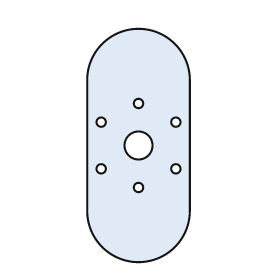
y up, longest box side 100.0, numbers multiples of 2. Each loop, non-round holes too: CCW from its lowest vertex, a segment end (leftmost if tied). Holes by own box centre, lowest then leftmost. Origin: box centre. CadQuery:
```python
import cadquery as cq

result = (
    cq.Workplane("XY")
    .moveTo(-22.0, -28.0)
    .threePointArc((0.0, -50.0), (22.0, -28.0))
    .lineTo(22.0, 28.0)
    .threePointArc((0.0, 50.0), (-22.0, 28.0))
    .close()
    .moveTo(0.0, -18.0)
    .circle(2.0)
    .moveTo(-16.0, -10.0)
    .circle(2.0)
    .moveTo(16.0, -10.0)
    .circle(2.0)
    .moveTo(0.0, 0.0)
    .circle(6.0)
    .moveTo(-16.0, 10.0)
    .circle(2.0)
    .moveTo(16.0, 10.0)
    .circle(2.0)
    .moveTo(0.0, 18.0)
    .circle(2.0)
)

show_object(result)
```